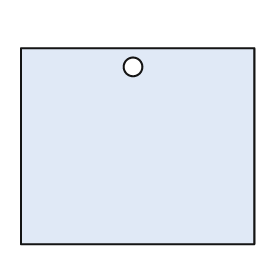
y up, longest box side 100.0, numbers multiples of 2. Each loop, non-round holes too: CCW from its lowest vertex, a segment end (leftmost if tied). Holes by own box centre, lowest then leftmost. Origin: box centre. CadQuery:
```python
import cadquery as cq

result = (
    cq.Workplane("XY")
    .moveTo(-50.0, -42.0)
    .lineTo(50.0, -42.0)
    .lineTo(50.0, 42.0)
    .lineTo(-50.0, 42.0)
    .close()
    .moveTo(-2.0, 34.0)
    .circle(4.0)
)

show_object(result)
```